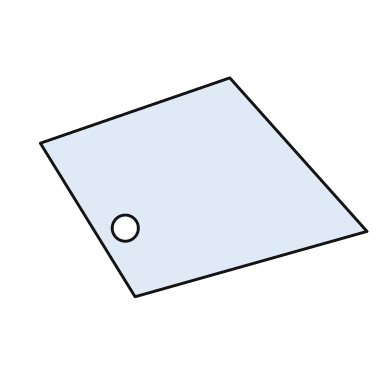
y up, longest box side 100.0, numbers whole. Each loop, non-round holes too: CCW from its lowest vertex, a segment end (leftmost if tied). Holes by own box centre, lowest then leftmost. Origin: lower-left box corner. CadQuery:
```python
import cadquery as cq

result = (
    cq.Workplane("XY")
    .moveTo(29.0, 0.0)
    .lineTo(100.0, 20.0)
    .lineTo(58.0, 67.0)
    .lineTo(0.0, 47.0)
    .close()
    .moveTo(26.0, 21.0)
    .circle(4.0)
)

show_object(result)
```